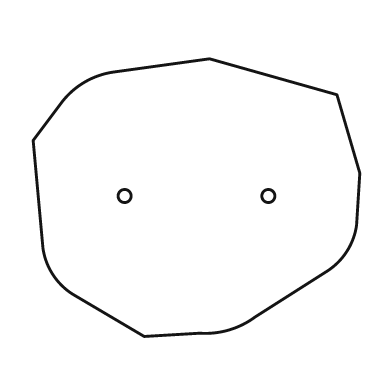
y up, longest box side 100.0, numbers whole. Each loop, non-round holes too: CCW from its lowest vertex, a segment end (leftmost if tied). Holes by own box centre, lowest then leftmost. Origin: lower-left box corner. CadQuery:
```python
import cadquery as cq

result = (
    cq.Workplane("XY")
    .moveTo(34.0, 0.0)
    .lineTo(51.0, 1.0)
    .threePointArc((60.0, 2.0), (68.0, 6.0))
    .lineTo(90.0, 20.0)
    .threePointArc((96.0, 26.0), (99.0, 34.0))
    .lineTo(100.0, 50.0)
    .lineTo(93.0, 74.0)
    .lineTo(54.0, 85.0)
    .lineTo(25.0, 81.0)
    .threePointArc((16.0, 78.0), (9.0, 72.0))
    .lineTo(0.0, 60.0)
    .lineTo(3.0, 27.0)
    .threePointArc((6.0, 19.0), (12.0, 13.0))
    .close()
    .moveTo(28.0, 43.0)
    .circle(2.0)
    .moveTo(72.0, 43.0)
    .circle(2.0)
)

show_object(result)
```